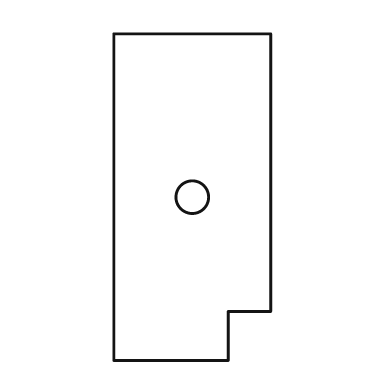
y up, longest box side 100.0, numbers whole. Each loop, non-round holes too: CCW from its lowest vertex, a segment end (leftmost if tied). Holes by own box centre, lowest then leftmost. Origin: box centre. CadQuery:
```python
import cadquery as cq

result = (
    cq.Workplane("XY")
    .moveTo(-24.0, -50.0)
    .lineTo(11.0, -50.0)
    .lineTo(11.0, -35.0)
    .lineTo(24.0, -35.0)
    .lineTo(24.0, 50.0)
    .lineTo(-24.0, 50.0)
    .close()
    .moveTo(0.0, 0.0)
    .circle(5.0)
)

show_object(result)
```